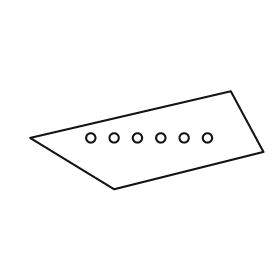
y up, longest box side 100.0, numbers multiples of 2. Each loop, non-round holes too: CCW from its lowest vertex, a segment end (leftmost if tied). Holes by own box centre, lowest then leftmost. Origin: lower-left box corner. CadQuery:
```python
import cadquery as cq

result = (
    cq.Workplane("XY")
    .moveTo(36.0, 0.0)
    .lineTo(100.0, 16.0)
    .lineTo(86.0, 42.0)
    .lineTo(0.0, 22.0)
    .close()
    .moveTo(26.0, 22.0)
    .circle(2.0)
    .moveTo(36.0, 22.0)
    .circle(2.0)
    .moveTo(46.0, 22.0)
    .circle(2.0)
    .moveTo(56.0, 22.0)
    .circle(2.0)
    .moveTo(66.0, 22.0)
    .circle(2.0)
    .moveTo(76.0, 22.0)
    .circle(2.0)
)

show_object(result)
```